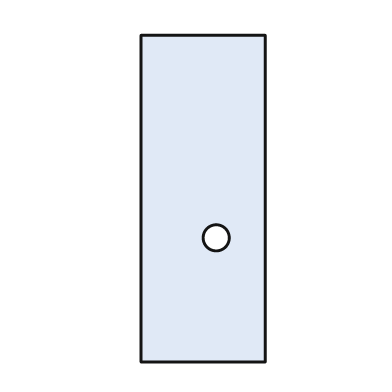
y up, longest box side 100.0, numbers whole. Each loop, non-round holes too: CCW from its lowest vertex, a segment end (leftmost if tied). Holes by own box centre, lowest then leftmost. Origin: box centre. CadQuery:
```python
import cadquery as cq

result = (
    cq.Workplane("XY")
    .moveTo(-19.0, -50.0)
    .lineTo(19.0, -50.0)
    .lineTo(19.0, 50.0)
    .lineTo(-19.0, 50.0)
    .close()
    .moveTo(4.0, -12.0)
    .circle(4.0)
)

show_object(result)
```